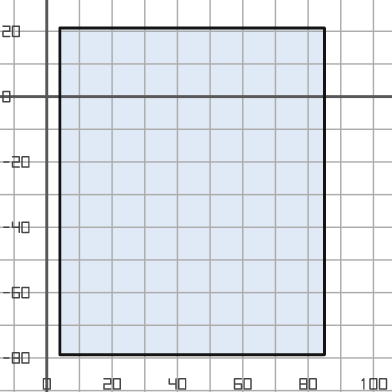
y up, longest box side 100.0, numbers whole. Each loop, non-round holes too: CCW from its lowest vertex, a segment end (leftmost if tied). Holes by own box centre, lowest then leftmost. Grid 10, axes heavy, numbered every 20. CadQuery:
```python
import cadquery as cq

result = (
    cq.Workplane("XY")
    .moveTo(4.0, -79.0)
    .lineTo(85.0, -79.0)
    .lineTo(85.0, 21.0)
    .lineTo(4.0, 21.0)
    .close()
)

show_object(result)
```